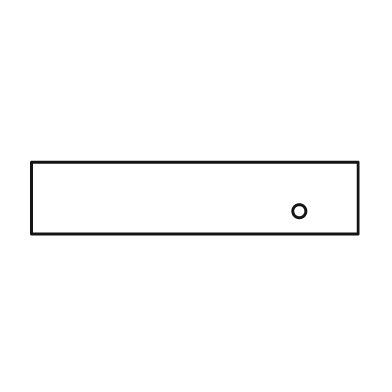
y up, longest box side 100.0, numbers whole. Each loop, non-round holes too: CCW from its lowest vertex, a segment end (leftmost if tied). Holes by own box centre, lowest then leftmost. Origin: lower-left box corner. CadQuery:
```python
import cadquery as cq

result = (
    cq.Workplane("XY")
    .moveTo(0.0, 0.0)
    .lineTo(100.0, 0.0)
    .lineTo(100.0, 22.0)
    .lineTo(0.0, 22.0)
    .close()
    .moveTo(82.0, 7.0)
    .circle(2.0)
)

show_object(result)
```